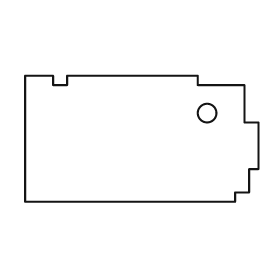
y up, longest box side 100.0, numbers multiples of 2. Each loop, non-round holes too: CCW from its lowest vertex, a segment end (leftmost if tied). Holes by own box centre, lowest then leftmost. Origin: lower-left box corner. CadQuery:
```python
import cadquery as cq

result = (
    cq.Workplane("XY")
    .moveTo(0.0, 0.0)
    .lineTo(90.0, 0.0)
    .lineTo(90.0, 4.0)
    .lineTo(96.0, 4.0)
    .lineTo(96.0, 14.0)
    .lineTo(100.0, 14.0)
    .lineTo(100.0, 34.0)
    .lineTo(94.0, 34.0)
    .lineTo(94.0, 50.0)
    .lineTo(74.0, 50.0)
    .lineTo(74.0, 54.0)
    .lineTo(18.0, 54.0)
    .lineTo(18.0, 50.0)
    .lineTo(12.0, 50.0)
    .lineTo(12.0, 54.0)
    .lineTo(0.0, 54.0)
    .close()
    .moveTo(78.0, 38.0)
    .circle(4.0)
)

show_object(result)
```